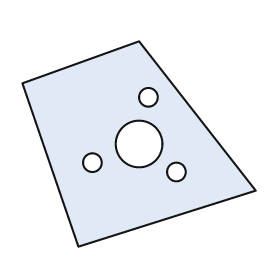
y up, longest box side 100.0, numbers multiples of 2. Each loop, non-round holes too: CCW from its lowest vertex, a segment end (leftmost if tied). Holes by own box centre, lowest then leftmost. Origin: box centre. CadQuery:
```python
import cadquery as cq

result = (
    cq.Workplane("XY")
    .moveTo(-26.0, -44.0)
    .lineTo(50.0, -20.0)
    .lineTo(0.0, 44.0)
    .lineTo(-50.0, 26.0)
    .close()
    .moveTo(16.0, -12.0)
    .circle(4.0)
    .moveTo(-20.0, -8.0)
    .circle(4.0)
    .moveTo(0.0, 0.0)
    .circle(10.0)
    .moveTo(4.0, 20.0)
    .circle(4.0)
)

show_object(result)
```